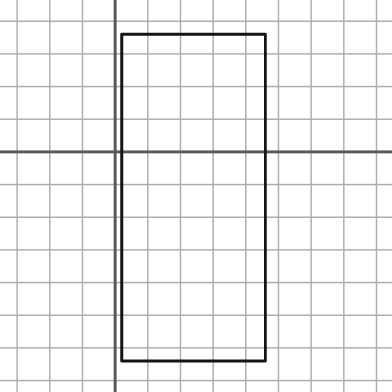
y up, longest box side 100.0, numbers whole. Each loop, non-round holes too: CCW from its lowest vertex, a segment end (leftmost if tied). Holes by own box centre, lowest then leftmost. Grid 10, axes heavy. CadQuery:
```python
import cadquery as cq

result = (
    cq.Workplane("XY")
    .moveTo(2.0, -64.0)
    .lineTo(46.0, -64.0)
    .lineTo(46.0, 36.0)
    .lineTo(2.0, 36.0)
    .close()
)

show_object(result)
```